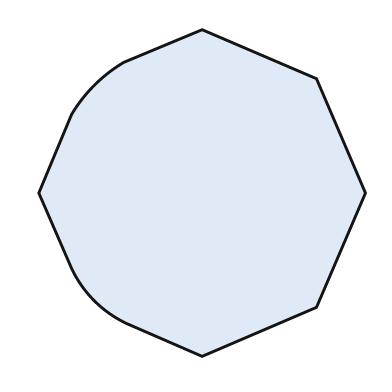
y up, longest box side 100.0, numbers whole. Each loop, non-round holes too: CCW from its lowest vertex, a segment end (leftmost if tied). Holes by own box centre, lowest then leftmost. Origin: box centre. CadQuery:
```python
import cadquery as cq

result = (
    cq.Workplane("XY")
    .moveTo(0.0, -50.0)
    .lineTo(35.0, -35.0)
    .lineTo(50.0, 0.0)
    .lineTo(35.0, 35.0)
    .lineTo(0.0, 50.0)
    .lineTo(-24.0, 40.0)
    .threePointArc((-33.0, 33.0), (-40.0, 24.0))
    .lineTo(-50.0, 0.0)
    .lineTo(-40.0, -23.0)
    .threePointArc((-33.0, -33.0), (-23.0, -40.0))
    .close()
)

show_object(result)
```